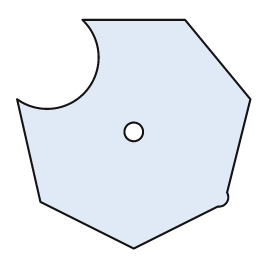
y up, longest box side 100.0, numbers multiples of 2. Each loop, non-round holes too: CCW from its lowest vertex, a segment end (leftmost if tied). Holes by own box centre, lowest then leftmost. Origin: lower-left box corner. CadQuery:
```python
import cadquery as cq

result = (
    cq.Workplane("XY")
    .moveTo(50.0, 0.0)
    .lineTo(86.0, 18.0)
    .threePointArc((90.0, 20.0), (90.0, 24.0))
    .lineTo(100.0, 64.0)
    .lineTo(72.0, 98.0)
    .lineTo(28.0, 98.0)
    .threePointArc((30.0, 68.0), (0.0, 64.0))
    .lineTo(10.0, 20.0)
    .close()
    .moveTo(50.0, 50.0)
    .circle(4.0)
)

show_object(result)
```